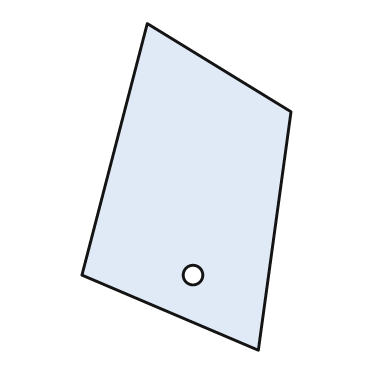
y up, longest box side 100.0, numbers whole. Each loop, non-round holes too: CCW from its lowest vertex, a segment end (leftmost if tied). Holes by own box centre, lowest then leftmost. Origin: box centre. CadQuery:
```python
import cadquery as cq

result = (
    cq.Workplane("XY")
    .moveTo(22.0, -50.0)
    .lineTo(32.0, 23.0)
    .lineTo(-12.0, 50.0)
    .lineTo(-32.0, -27.0)
    .close()
    .moveTo(2.0, -27.0)
    .circle(3.0)
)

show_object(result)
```